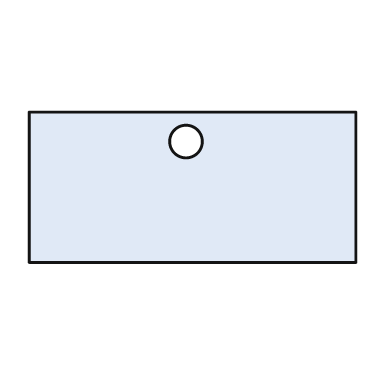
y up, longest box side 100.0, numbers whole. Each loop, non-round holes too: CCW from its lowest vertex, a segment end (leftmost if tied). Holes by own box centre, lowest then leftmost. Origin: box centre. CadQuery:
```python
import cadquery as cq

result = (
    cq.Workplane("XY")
    .moveTo(-50.0, -23.0)
    .lineTo(50.0, -23.0)
    .lineTo(50.0, 23.0)
    .lineTo(-50.0, 23.0)
    .close()
    .moveTo(-2.0, 14.0)
    .circle(5.0)
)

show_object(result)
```